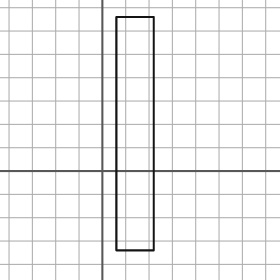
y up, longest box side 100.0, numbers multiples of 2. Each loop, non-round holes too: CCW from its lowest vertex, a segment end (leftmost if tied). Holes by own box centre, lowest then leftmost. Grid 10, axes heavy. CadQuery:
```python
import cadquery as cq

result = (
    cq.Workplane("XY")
    .moveTo(6.0, -34.0)
    .lineTo(22.0, -34.0)
    .lineTo(22.0, 66.0)
    .lineTo(6.0, 66.0)
    .close()
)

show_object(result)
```